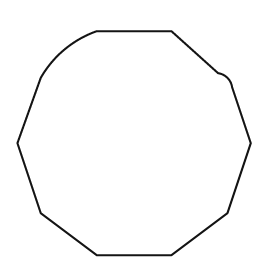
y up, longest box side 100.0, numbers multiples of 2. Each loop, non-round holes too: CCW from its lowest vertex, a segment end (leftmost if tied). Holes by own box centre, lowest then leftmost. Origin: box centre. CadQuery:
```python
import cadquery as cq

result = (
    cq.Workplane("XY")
    .moveTo(-16.0, -48.0)
    .lineTo(16.0, -48.0)
    .lineTo(40.0, -30.0)
    .lineTo(50.0, 0.0)
    .lineTo(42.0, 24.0)
    .threePointArc((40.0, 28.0), (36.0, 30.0))
    .lineTo(16.0, 48.0)
    .lineTo(-16.0, 48.0)
    .threePointArc((-30.0, 40.0), (-40.0, 28.0))
    .lineTo(-50.0, 0.0)
    .lineTo(-40.0, -30.0)
    .close()
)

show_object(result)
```